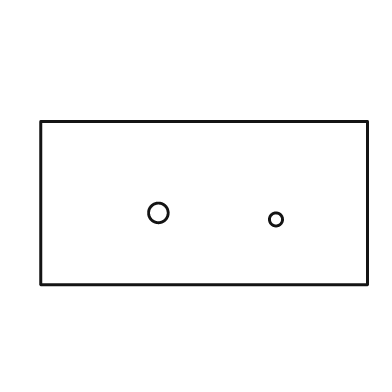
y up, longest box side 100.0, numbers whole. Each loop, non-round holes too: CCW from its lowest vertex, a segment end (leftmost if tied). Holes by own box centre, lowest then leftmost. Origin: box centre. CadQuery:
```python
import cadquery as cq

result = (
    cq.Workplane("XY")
    .moveTo(-50.0, -25.0)
    .lineTo(50.0, -25.0)
    .lineTo(50.0, 25.0)
    .lineTo(-50.0, 25.0)
    .close()
    .moveTo(22.0, -5.0)
    .circle(2.0)
    .moveTo(-14.0, -3.0)
    .circle(3.0)
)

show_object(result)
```